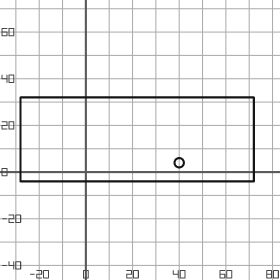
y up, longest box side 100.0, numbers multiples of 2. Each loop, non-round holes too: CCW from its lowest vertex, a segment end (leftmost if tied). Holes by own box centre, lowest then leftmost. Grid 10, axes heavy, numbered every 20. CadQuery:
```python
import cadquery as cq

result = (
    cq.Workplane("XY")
    .moveTo(-28.0, -4.0)
    .lineTo(72.0, -4.0)
    .lineTo(72.0, 32.0)
    .lineTo(-28.0, 32.0)
    .close()
    .moveTo(40.0, 4.0)
    .circle(2.0)
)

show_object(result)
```